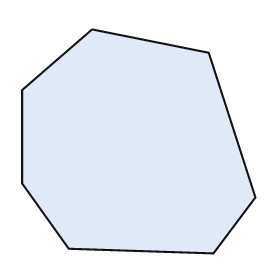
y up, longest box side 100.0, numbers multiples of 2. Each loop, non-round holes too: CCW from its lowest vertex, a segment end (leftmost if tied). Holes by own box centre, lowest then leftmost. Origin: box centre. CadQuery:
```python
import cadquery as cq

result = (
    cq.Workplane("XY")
    .moveTo(32.0, -48.0)
    .lineTo(50.0, -24.0)
    .lineTo(30.0, 38.0)
    .lineTo(-20.0, 48.0)
    .lineTo(-50.0, 22.0)
    .lineTo(-50.0, -18.0)
    .lineTo(-30.0, -46.0)
    .close()
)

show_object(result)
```